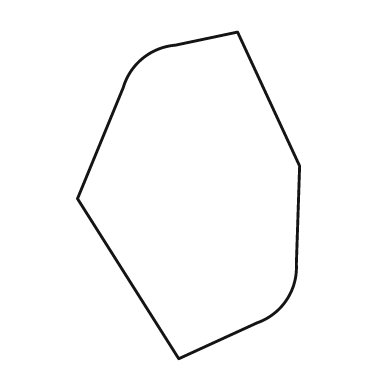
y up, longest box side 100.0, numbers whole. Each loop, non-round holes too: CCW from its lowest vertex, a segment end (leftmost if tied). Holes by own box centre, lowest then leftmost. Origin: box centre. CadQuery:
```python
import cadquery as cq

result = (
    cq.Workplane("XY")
    .moveTo(-3.0, -50.0)
    .lineTo(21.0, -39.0)
    .threePointArc((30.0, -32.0), (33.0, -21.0))
    .lineTo(34.0, 9.0)
    .lineTo(15.0, 50.0)
    .lineTo(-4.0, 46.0)
    .threePointArc((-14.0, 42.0), (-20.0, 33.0))
    .lineTo(-34.0, -1.0)
    .close()
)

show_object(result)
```